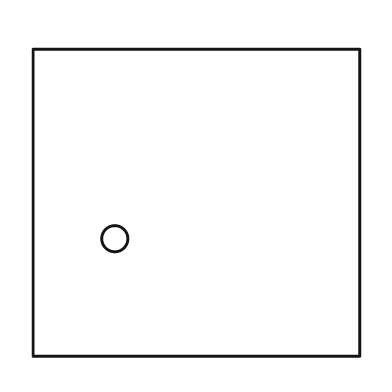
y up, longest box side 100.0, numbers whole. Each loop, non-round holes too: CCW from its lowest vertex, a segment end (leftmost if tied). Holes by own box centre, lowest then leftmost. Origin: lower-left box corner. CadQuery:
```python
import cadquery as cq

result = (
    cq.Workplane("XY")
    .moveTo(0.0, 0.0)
    .lineTo(100.0, 0.0)
    .lineTo(100.0, 94.0)
    .lineTo(0.0, 94.0)
    .close()
    .moveTo(25.0, 36.0)
    .circle(4.0)
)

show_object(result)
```